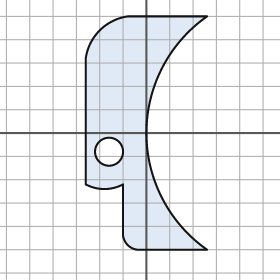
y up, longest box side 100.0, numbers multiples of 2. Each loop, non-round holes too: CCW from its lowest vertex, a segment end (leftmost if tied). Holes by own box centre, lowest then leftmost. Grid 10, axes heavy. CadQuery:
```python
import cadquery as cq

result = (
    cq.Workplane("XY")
    .moveTo(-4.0, -50.0)
    .lineTo(26.0, -50.0)
    .threePointArc((0.0, 0.0), (26.0, 50.0))
    .lineTo(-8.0, 50.0)
    .threePointArc((-20.0, 44.0), (-26.0, 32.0))
    .lineTo(-26.0, -22.0)
    .threePointArc((-18.0, -24.0), (-10.0, -22.0))
    .lineTo(-10.0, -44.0)
    .threePointArc((-8.0, -48.0), (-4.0, -50.0))
    .close()
    .moveTo(-16.0, -8.0)
    .circle(6.0)
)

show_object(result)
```